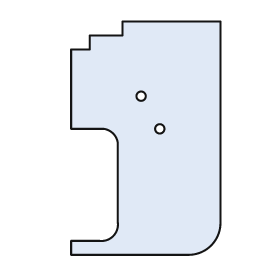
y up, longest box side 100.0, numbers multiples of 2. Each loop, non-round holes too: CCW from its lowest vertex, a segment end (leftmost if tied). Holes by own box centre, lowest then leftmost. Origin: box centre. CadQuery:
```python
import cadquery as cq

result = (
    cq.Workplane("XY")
    .moveTo(-32.0, -50.0)
    .lineTo(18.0, -50.0)
    .threePointArc((28.0, -46.0), (32.0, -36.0))
    .lineTo(32.0, 50.0)
    .lineTo(-10.0, 50.0)
    .lineTo(-10.0, 44.0)
    .lineTo(-24.0, 44.0)
    .lineTo(-24.0, 38.0)
    .lineTo(-32.0, 38.0)
    .lineTo(-32.0, 4.0)
    .lineTo(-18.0, 4.0)
    .threePointArc((-14.0, 2.0), (-12.0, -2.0))
    .lineTo(-12.0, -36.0)
    .threePointArc((-14.0, -42.0), (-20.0, -44.0))
    .lineTo(-32.0, -44.0)
    .close()
    .moveTo(6.0, 4.0)
    .circle(2.0)
    .moveTo(-2.0, 18.0)
    .circle(2.0)
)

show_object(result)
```